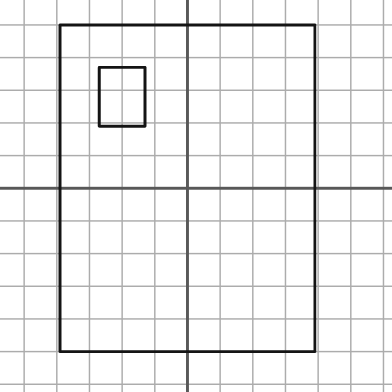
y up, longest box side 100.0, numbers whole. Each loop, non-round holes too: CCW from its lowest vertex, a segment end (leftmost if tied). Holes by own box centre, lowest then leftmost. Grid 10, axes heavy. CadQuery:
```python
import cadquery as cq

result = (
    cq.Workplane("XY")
    .moveTo(-39.0, -50.0)
    .lineTo(39.0, -50.0)
    .lineTo(39.0, 50.0)
    .lineTo(-39.0, 50.0)
    .close()
    .moveTo(-27.0, 19.0)
    .lineTo(-13.0, 19.0)
    .lineTo(-13.0, 37.0)
    .lineTo(-27.0, 37.0)
    .close()
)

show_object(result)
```